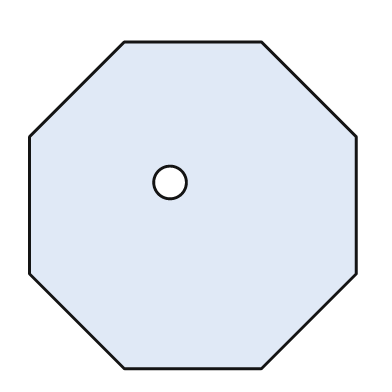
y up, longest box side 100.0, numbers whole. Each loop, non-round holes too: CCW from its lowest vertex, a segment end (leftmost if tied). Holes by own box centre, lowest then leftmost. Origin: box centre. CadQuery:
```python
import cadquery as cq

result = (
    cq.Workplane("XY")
    .moveTo(-21.0, -50.0)
    .lineTo(21.0, -50.0)
    .lineTo(50.0, -21.0)
    .lineTo(50.0, 21.0)
    .lineTo(21.0, 50.0)
    .lineTo(-21.0, 50.0)
    .lineTo(-50.0, 21.0)
    .lineTo(-50.0, -21.0)
    .close()
    .moveTo(-7.0, 7.0)
    .circle(5.0)
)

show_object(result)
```